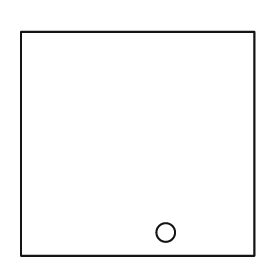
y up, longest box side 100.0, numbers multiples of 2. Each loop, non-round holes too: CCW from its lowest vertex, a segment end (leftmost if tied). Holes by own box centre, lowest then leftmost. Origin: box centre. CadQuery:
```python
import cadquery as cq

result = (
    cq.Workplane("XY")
    .moveTo(-50.0, -48.0)
    .lineTo(50.0, -48.0)
    .lineTo(50.0, 48.0)
    .lineTo(-50.0, 48.0)
    .close()
    .moveTo(12.0, -38.0)
    .circle(4.0)
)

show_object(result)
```